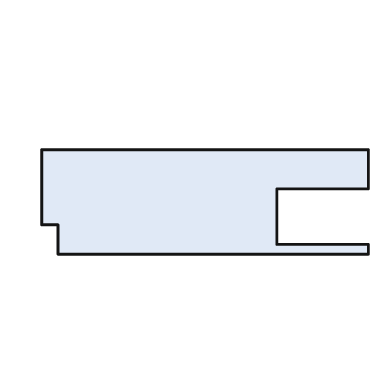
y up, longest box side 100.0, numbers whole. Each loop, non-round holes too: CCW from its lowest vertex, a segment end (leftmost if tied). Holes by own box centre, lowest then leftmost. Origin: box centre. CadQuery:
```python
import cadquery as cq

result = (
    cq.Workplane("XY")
    .moveTo(-45.0, -16.0)
    .lineTo(50.0, -16.0)
    .lineTo(50.0, -13.0)
    .lineTo(22.0, -13.0)
    .lineTo(22.0, 4.0)
    .lineTo(50.0, 4.0)
    .lineTo(50.0, 16.0)
    .lineTo(-50.0, 16.0)
    .lineTo(-50.0, -7.0)
    .lineTo(-45.0, -7.0)
    .close()
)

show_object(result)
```